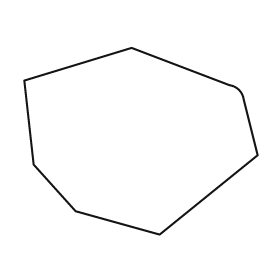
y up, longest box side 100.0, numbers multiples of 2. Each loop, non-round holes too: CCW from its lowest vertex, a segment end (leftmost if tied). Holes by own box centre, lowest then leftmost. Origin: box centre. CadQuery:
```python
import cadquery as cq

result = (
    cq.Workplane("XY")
    .moveTo(8.0, -40.0)
    .lineTo(50.0, -6.0)
    .lineTo(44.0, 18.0)
    .threePointArc((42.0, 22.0), (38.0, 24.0))
    .lineTo(-4.0, 40.0)
    .lineTo(-50.0, 26.0)
    .lineTo(-46.0, -10.0)
    .lineTo(-28.0, -30.0)
    .close()
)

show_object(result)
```